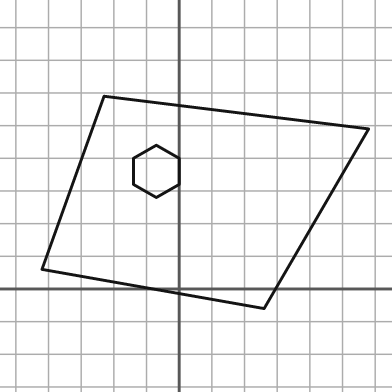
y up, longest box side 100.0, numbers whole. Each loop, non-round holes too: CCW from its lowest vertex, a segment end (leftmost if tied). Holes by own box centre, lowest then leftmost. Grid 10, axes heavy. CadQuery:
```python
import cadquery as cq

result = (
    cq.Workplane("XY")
    .moveTo(26.0, -6.0)
    .lineTo(58.0, 49.0)
    .lineTo(-23.0, 59.0)
    .lineTo(-42.0, 6.0)
    .close()
    .moveTo(-7.0, 28.0)
    .lineTo(0.0, 32.0)
    .lineTo(0.0, 40.0)
    .lineTo(-7.0, 44.0)
    .lineTo(-14.0, 40.0)
    .lineTo(-14.0, 32.0)
    .close()
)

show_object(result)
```